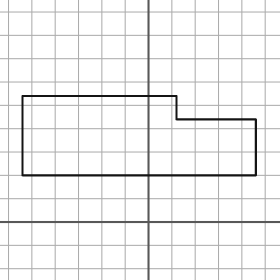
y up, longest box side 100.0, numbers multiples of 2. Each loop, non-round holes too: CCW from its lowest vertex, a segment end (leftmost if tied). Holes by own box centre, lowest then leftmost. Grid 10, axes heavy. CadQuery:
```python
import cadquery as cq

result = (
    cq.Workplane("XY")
    .moveTo(-54.0, 20.0)
    .lineTo(46.0, 20.0)
    .lineTo(46.0, 44.0)
    .lineTo(12.0, 44.0)
    .lineTo(12.0, 54.0)
    .lineTo(-54.0, 54.0)
    .close()
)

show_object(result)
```